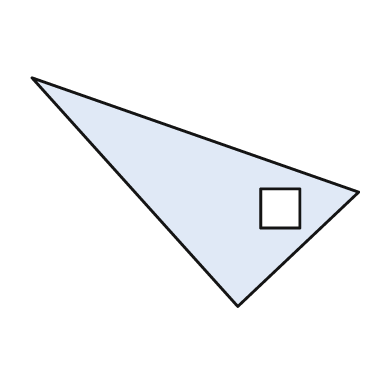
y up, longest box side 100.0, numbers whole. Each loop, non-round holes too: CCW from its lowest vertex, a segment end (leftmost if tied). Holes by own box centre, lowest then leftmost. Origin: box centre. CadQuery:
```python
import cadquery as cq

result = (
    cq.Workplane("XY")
    .moveTo(13.0, -35.0)
    .lineTo(50.0, 0.0)
    .lineTo(-50.0, 35.0)
    .close()
    .moveTo(20.0, -11.0)
    .lineTo(32.0, -11.0)
    .lineTo(32.0, 1.0)
    .lineTo(20.0, 1.0)
    .close()
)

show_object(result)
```